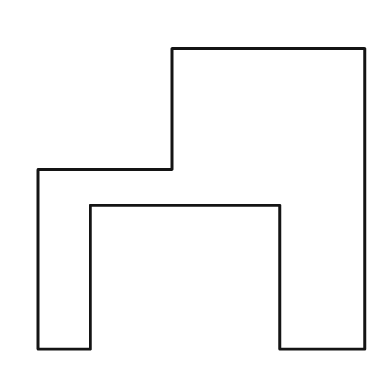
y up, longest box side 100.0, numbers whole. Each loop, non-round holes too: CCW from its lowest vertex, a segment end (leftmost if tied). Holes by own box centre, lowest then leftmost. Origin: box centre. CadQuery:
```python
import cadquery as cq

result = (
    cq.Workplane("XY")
    .moveTo(-50.0, -46.0)
    .lineTo(-34.0, -46.0)
    .lineTo(-34.0, -2.0)
    .lineTo(24.0, -2.0)
    .lineTo(24.0, -46.0)
    .lineTo(50.0, -46.0)
    .lineTo(50.0, 46.0)
    .lineTo(-9.0, 46.0)
    .lineTo(-9.0, 9.0)
    .lineTo(-50.0, 9.0)
    .close()
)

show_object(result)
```